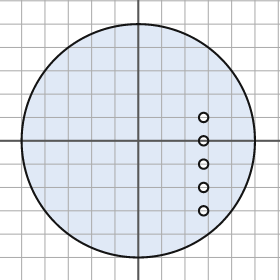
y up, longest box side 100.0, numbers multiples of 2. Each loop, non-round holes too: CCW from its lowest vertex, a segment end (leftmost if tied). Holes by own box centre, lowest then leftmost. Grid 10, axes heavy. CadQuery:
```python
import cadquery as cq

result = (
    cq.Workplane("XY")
    .moveTo(0.0, 0.0)
    .circle(50.0)
    .moveTo(28.0, -30.0)
    .circle(2.0)
    .moveTo(28.0, -20.0)
    .circle(2.0)
    .moveTo(28.0, -10.0)
    .circle(2.0)
    .moveTo(28.0, 0.0)
    .circle(2.0)
    .moveTo(28.0, 10.0)
    .circle(2.0)
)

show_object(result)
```